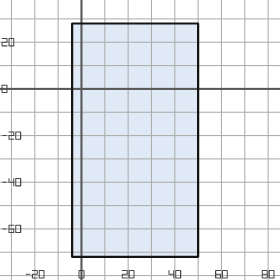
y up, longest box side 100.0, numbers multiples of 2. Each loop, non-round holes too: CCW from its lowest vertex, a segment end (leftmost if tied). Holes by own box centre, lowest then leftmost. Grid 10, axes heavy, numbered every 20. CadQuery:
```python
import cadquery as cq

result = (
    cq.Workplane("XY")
    .moveTo(-4.0, -72.0)
    .lineTo(50.0, -72.0)
    .lineTo(50.0, 28.0)
    .lineTo(-4.0, 28.0)
    .close()
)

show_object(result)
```